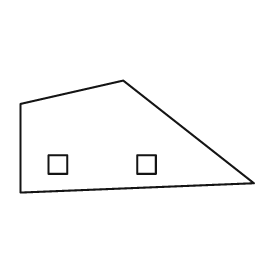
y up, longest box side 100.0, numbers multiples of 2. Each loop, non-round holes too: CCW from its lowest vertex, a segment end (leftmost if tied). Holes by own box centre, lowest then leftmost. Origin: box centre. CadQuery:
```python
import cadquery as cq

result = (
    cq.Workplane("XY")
    .moveTo(-50.0, -24.0)
    .lineTo(50.0, -20.0)
    .lineTo(-6.0, 24.0)
    .lineTo(-50.0, 14.0)
    .close()
    .moveTo(-38.0, -16.0)
    .lineTo(-30.0, -16.0)
    .lineTo(-30.0, -8.0)
    .lineTo(-38.0, -8.0)
    .close()
    .moveTo(0.0, -16.0)
    .lineTo(8.0, -16.0)
    .lineTo(8.0, -8.0)
    .lineTo(0.0, -8.0)
    .close()
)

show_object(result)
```